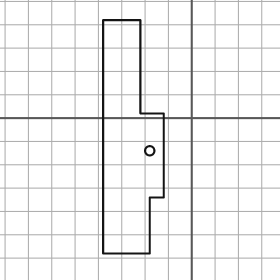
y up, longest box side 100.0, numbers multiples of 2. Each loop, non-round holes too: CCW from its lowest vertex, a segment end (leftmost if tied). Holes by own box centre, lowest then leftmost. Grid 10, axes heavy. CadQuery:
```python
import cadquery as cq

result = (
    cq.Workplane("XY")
    .moveTo(-38.0, -58.0)
    .lineTo(-18.0, -58.0)
    .lineTo(-18.0, -34.0)
    .lineTo(-12.0, -34.0)
    .lineTo(-12.0, 2.0)
    .lineTo(-22.0, 2.0)
    .lineTo(-22.0, 42.0)
    .lineTo(-38.0, 42.0)
    .close()
    .moveTo(-18.0, -14.0)
    .circle(2.0)
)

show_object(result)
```